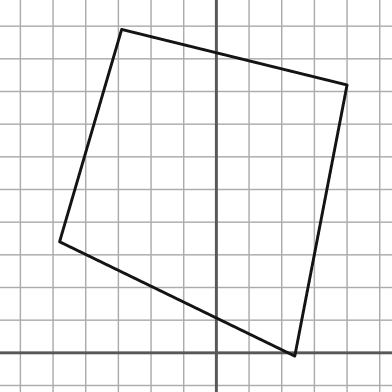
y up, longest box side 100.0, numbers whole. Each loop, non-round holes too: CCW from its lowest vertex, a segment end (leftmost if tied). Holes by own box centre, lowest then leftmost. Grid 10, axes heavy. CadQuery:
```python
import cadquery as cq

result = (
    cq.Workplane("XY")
    .moveTo(24.0, -1.0)
    .lineTo(40.0, 82.0)
    .lineTo(-29.0, 99.0)
    .lineTo(-48.0, 34.0)
    .close()
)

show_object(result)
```